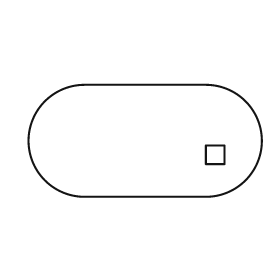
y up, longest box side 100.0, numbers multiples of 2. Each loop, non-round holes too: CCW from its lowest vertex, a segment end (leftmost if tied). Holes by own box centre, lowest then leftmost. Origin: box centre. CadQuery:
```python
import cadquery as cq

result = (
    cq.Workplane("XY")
    .moveTo(-26.0, -24.0)
    .lineTo(26.0, -24.0)
    .threePointArc((50.0, 0.0), (26.0, 24.0))
    .lineTo(-26.0, 24.0)
    .threePointArc((-50.0, 0.0), (-26.0, -24.0))
    .close()
    .moveTo(26.0, -10.0)
    .lineTo(34.0, -10.0)
    .lineTo(34.0, -2.0)
    .lineTo(26.0, -2.0)
    .close()
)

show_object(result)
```